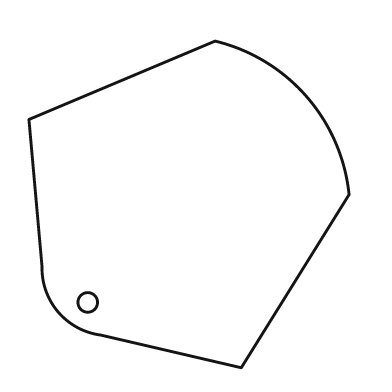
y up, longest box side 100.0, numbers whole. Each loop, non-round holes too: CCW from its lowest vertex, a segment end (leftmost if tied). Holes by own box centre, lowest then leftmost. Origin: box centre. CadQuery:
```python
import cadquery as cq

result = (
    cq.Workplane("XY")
    .moveTo(16.0, -50.0)
    .lineTo(49.0, 3.0)
    .threePointArc((36.0, 33.0), (8.0, 50.0))
    .lineTo(-49.0, 26.0)
    .lineTo(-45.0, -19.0)
    .threePointArc((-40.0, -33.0), (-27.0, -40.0))
    .close()
    .moveTo(-31.0, -30.0)
    .circle(3.0)
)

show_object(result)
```